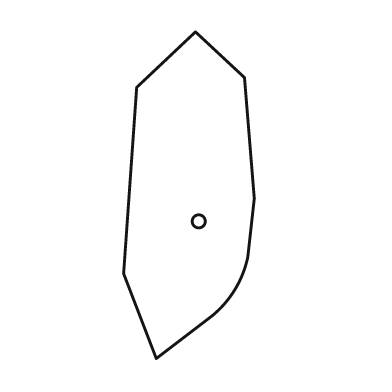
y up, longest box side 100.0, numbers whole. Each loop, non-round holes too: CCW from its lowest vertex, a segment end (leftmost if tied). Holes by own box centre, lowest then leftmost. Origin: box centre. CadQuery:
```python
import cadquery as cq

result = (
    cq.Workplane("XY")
    .moveTo(-10.0, -50.0)
    .lineTo(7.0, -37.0)
    .threePointArc((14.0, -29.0), (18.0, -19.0))
    .lineTo(20.0, -1.0)
    .lineTo(17.0, 36.0)
    .lineTo(2.0, 50.0)
    .lineTo(-16.0, 33.0)
    .lineTo(-20.0, -24.0)
    .close()
    .moveTo(3.0, -8.0)
    .circle(2.0)
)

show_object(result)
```